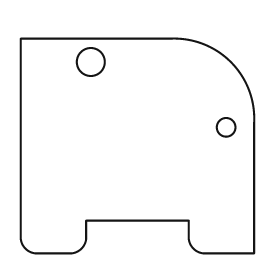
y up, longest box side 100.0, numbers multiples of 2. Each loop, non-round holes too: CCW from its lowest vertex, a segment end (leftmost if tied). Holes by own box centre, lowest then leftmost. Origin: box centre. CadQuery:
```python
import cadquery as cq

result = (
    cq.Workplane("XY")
    .moveTo(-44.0, -46.0)
    .lineTo(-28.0, -46.0)
    .threePointArc((-24.0, -44.0), (-22.0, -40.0))
    .lineTo(-22.0, -32.0)
    .lineTo(22.0, -32.0)
    .lineTo(22.0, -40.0)
    .threePointArc((24.0, -44.0), (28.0, -46.0))
    .lineTo(50.0, -46.0)
    .lineTo(50.0, 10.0)
    .threePointArc((40.0, 36.0), (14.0, 46.0))
    .lineTo(-50.0, 46.0)
    .lineTo(-50.0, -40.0)
    .threePointArc((-48.0, -44.0), (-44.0, -46.0))
    .close()
    .moveTo(38.0, 8.0)
    .circle(4.0)
    .moveTo(-20.0, 36.0)
    .circle(6.0)
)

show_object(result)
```